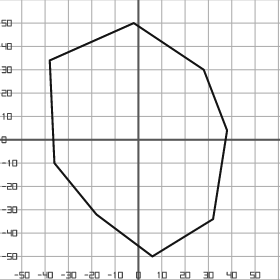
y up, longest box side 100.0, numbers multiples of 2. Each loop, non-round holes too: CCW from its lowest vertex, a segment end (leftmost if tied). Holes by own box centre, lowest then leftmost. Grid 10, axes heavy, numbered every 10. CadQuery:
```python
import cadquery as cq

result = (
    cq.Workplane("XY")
    .moveTo(6.0, -50.0)
    .lineTo(32.0, -34.0)
    .lineTo(38.0, 4.0)
    .lineTo(28.0, 30.0)
    .lineTo(-2.0, 50.0)
    .lineTo(-38.0, 34.0)
    .lineTo(-36.0, -10.0)
    .lineTo(-18.0, -32.0)
    .close()
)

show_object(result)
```